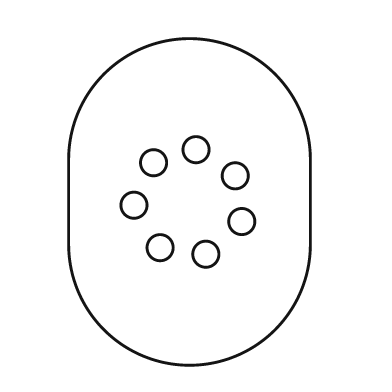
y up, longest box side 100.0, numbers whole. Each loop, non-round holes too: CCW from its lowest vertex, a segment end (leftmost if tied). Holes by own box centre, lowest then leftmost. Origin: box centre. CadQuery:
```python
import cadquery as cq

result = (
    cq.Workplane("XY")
    .moveTo(-37.0, -13.0)
    .threePointArc((0.0, -50.0), (37.0, -13.0))
    .lineTo(37.0, 13.0)
    .threePointArc((0.0, 50.0), (-37.0, 13.0))
    .close()
    .moveTo(5.0, -16.0)
    .circle(4.0)
    .moveTo(-9.0, -14.0)
    .circle(4.0)
    .moveTo(16.0, -6.0)
    .circle(4.0)
    .moveTo(-17.0, -1.0)
    .circle(4.0)
    .moveTo(14.0, 8.0)
    .circle(4.0)
    .moveTo(-11.0, 12.0)
    .circle(4.0)
    .moveTo(2.0, 16.0)
    .circle(4.0)
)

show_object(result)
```